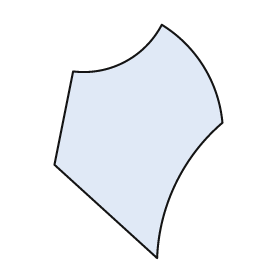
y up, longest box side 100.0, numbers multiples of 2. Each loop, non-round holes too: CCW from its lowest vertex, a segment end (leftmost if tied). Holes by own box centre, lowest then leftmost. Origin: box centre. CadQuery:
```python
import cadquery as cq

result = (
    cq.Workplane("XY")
    .moveTo(8.0, -50.0)
    .threePointArc((16.0, -18.0), (36.0, 8.0))
    .threePointArc((28.0, 32.0), (10.0, 50.0))
    .threePointArc((-6.0, 34.0), (-28.0, 30.0))
    .lineTo(-36.0, -10.0)
    .close()
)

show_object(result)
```